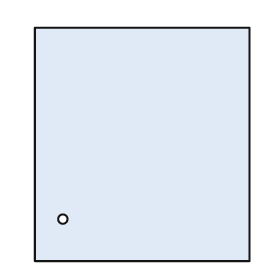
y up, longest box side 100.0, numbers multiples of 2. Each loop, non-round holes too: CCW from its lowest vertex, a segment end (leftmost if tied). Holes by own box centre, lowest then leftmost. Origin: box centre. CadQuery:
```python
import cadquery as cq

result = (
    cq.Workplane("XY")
    .moveTo(-46.0, -50.0)
    .lineTo(46.0, -50.0)
    .lineTo(46.0, 50.0)
    .lineTo(-46.0, 50.0)
    .close()
    .moveTo(-34.0, -32.0)
    .circle(2.0)
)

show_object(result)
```